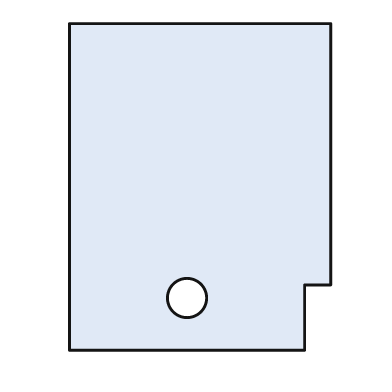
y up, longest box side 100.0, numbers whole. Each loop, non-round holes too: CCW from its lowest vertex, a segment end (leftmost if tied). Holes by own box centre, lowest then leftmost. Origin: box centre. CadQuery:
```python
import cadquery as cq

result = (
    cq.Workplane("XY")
    .moveTo(-40.0, -50.0)
    .lineTo(32.0, -50.0)
    .lineTo(32.0, -30.0)
    .lineTo(40.0, -30.0)
    .lineTo(40.0, 50.0)
    .lineTo(-40.0, 50.0)
    .close()
    .moveTo(-4.0, -34.0)
    .circle(6.0)
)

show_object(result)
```